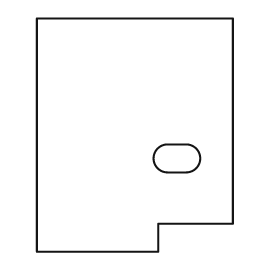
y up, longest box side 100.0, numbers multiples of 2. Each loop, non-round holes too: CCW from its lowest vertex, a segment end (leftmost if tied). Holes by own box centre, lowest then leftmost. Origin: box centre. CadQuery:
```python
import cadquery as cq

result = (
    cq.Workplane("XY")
    .moveTo(-42.0, -50.0)
    .lineTo(10.0, -50.0)
    .lineTo(10.0, -38.0)
    .lineTo(42.0, -38.0)
    .lineTo(42.0, 50.0)
    .lineTo(-42.0, 50.0)
    .close()
    .moveTo(14.0, -16.0)
    .lineTo(22.0, -16.0)
    .threePointArc((28.0, -10.0), (22.0, -4.0))
    .lineTo(14.0, -4.0)
    .threePointArc((8.0, -10.0), (14.0, -16.0))
    .close()
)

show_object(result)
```